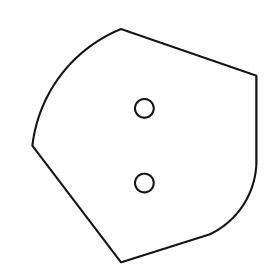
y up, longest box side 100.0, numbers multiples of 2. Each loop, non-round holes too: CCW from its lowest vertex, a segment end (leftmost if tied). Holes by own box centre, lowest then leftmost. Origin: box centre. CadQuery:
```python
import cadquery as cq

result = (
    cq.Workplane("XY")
    .moveTo(-10.0, -50.0)
    .lineTo(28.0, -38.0)
    .threePointArc((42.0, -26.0), (48.0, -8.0))
    .lineTo(48.0, 30.0)
    .lineTo(-10.0, 50.0)
    .threePointArc((-36.0, 30.0), (-48.0, 0.0))
    .close()
    .moveTo(0.0, -16.0)
    .circle(4.0)
    .moveTo(0.0, 16.0)
    .circle(4.0)
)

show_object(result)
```